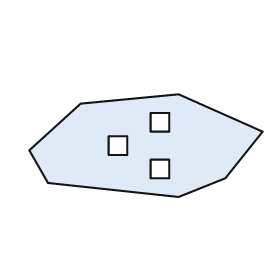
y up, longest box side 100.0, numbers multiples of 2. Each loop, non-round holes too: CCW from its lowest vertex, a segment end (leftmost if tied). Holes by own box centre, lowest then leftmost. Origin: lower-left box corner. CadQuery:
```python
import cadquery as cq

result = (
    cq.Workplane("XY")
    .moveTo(64.0, 0.0)
    .lineTo(84.0, 8.0)
    .lineTo(100.0, 28.0)
    .lineTo(64.0, 44.0)
    .lineTo(22.0, 40.0)
    .lineTo(0.0, 20.0)
    .lineTo(8.0, 6.0)
    .close()
    .moveTo(52.0, 8.0)
    .lineTo(60.0, 8.0)
    .lineTo(60.0, 16.0)
    .lineTo(52.0, 16.0)
    .close()
    .moveTo(34.0, 18.0)
    .lineTo(42.0, 18.0)
    .lineTo(42.0, 26.0)
    .lineTo(34.0, 26.0)
    .close()
    .moveTo(52.0, 28.0)
    .lineTo(60.0, 28.0)
    .lineTo(60.0, 36.0)
    .lineTo(52.0, 36.0)
    .close()
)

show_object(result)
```